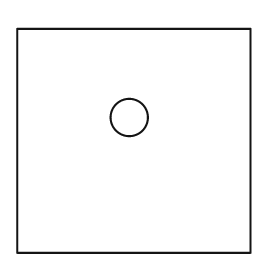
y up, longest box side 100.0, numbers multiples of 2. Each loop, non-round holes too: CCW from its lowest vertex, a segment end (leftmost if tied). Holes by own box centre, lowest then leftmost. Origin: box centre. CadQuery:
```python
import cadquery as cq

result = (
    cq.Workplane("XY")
    .moveTo(-50.0, -48.0)
    .lineTo(50.0, -48.0)
    .lineTo(50.0, 48.0)
    .lineTo(-50.0, 48.0)
    .close()
    .moveTo(-2.0, 10.0)
    .circle(8.0)
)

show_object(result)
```